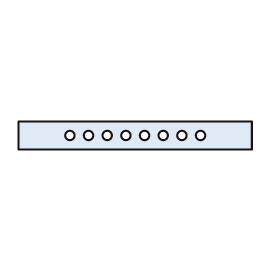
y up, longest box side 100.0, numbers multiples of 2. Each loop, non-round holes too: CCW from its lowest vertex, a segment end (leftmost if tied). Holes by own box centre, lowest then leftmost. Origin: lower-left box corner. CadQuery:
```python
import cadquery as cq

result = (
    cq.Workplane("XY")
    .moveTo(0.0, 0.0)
    .lineTo(100.0, 0.0)
    .lineTo(100.0, 12.0)
    .lineTo(0.0, 12.0)
    .close()
    .moveTo(22.0, 6.0)
    .circle(2.0)
    .moveTo(30.0, 6.0)
    .circle(2.0)
    .moveTo(38.0, 6.0)
    .circle(2.0)
    .moveTo(46.0, 6.0)
    .circle(2.0)
    .moveTo(54.0, 6.0)
    .circle(2.0)
    .moveTo(62.0, 6.0)
    .circle(2.0)
    .moveTo(70.0, 6.0)
    .circle(2.0)
    .moveTo(78.0, 6.0)
    .circle(2.0)
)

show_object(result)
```